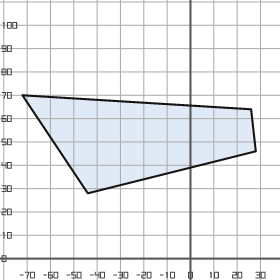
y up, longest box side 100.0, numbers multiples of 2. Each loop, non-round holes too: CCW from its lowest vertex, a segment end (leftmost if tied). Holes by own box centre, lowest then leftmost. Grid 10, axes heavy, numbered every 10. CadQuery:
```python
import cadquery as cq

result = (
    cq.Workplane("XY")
    .moveTo(-44.0, 28.0)
    .lineTo(28.0, 46.0)
    .lineTo(26.0, 64.0)
    .lineTo(-72.0, 70.0)
    .close()
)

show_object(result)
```